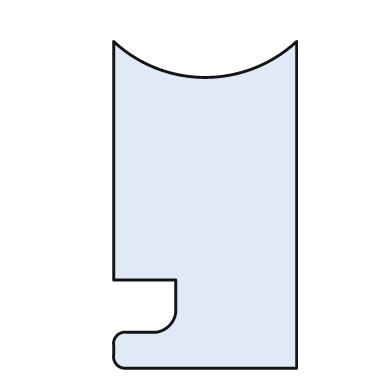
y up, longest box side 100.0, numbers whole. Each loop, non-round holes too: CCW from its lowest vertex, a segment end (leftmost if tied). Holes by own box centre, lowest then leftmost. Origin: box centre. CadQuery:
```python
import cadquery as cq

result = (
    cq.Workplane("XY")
    .moveTo(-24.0, -50.0)
    .lineTo(28.0, -50.0)
    .lineTo(28.0, 50.0)
    .threePointArc((0.0, 39.0), (-28.0, 50.0))
    .lineTo(-28.0, -23.0)
    .lineTo(-9.0, -23.0)
    .lineTo(-9.0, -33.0)
    .threePointArc((-11.0, -37.0), (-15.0, -39.0))
    .lineTo(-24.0, -39.0)
    .threePointArc((-27.0, -40.0), (-28.0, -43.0))
    .lineTo(-28.0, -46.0)
    .threePointArc((-27.0, -49.0), (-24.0, -50.0))
    .close()
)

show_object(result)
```